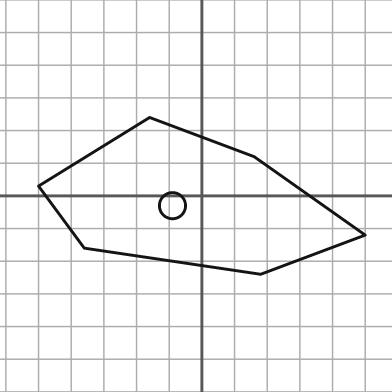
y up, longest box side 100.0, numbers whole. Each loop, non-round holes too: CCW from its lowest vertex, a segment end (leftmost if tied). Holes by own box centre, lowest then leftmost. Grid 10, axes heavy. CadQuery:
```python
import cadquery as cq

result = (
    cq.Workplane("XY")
    .moveTo(18.0, -24.0)
    .lineTo(50.0, -12.0)
    .lineTo(16.0, 12.0)
    .lineTo(-16.0, 24.0)
    .lineTo(-50.0, 3.0)
    .lineTo(-36.0, -16.0)
    .close()
    .moveTo(-9.0, -3.0)
    .circle(4.0)
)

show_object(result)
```